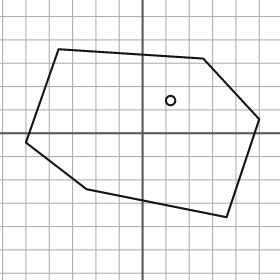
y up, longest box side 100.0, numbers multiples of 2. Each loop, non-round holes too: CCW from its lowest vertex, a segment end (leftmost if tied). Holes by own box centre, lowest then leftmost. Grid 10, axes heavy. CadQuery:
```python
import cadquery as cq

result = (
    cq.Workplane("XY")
    .moveTo(36.0, -36.0)
    .lineTo(50.0, 6.0)
    .lineTo(26.0, 32.0)
    .lineTo(-36.0, 36.0)
    .lineTo(-50.0, -4.0)
    .lineTo(-24.0, -24.0)
    .close()
    .moveTo(12.0, 14.0)
    .circle(2.0)
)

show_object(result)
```